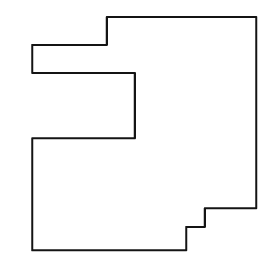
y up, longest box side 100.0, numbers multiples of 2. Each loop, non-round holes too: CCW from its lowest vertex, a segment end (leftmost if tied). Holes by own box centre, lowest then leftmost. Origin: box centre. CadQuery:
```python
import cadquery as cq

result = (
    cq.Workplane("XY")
    .moveTo(-48.0, -50.0)
    .lineTo(18.0, -50.0)
    .lineTo(18.0, -40.0)
    .lineTo(26.0, -40.0)
    .lineTo(26.0, -32.0)
    .lineTo(48.0, -32.0)
    .lineTo(48.0, 50.0)
    .lineTo(-16.0, 50.0)
    .lineTo(-16.0, 38.0)
    .lineTo(-48.0, 38.0)
    .lineTo(-48.0, 26.0)
    .lineTo(-4.0, 26.0)
    .lineTo(-4.0, -2.0)
    .lineTo(-48.0, -2.0)
    .close()
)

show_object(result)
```